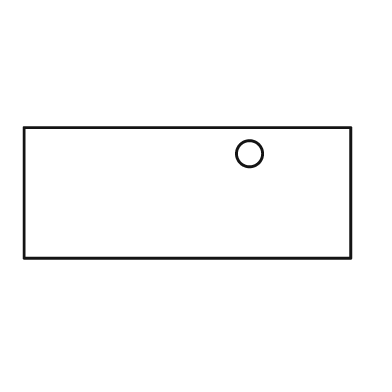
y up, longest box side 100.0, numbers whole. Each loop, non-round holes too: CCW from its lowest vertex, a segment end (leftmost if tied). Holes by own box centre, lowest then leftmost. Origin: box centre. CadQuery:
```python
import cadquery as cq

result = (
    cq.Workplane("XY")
    .moveTo(-50.0, -20.0)
    .lineTo(50.0, -20.0)
    .lineTo(50.0, 20.0)
    .lineTo(-50.0, 20.0)
    .close()
    .moveTo(19.0, 12.0)
    .circle(4.0)
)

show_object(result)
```